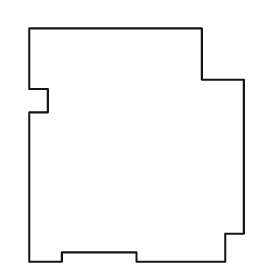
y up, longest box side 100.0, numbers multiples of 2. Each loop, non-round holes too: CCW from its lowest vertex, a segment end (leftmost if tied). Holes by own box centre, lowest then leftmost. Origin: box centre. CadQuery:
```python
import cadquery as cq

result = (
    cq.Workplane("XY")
    .moveTo(-46.0, -50.0)
    .lineTo(-32.0, -50.0)
    .lineTo(-32.0, -46.0)
    .lineTo(0.0, -46.0)
    .lineTo(0.0, -50.0)
    .lineTo(38.0, -50.0)
    .lineTo(38.0, -38.0)
    .lineTo(46.0, -38.0)
    .lineTo(46.0, 28.0)
    .lineTo(28.0, 28.0)
    .lineTo(28.0, 50.0)
    .lineTo(-46.0, 50.0)
    .lineTo(-46.0, 24.0)
    .lineTo(-38.0, 24.0)
    .lineTo(-38.0, 14.0)
    .lineTo(-46.0, 14.0)
    .close()
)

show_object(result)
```